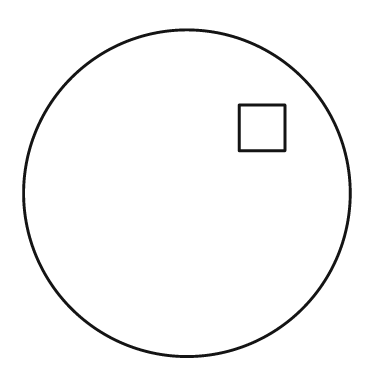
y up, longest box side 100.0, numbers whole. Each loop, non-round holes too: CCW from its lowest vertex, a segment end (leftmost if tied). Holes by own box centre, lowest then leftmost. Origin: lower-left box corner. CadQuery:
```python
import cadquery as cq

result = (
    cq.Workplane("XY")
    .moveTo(50.0, 50.0)
    .circle(50.0)
    .moveTo(66.0, 63.0)
    .lineTo(80.0, 63.0)
    .lineTo(80.0, 77.0)
    .lineTo(66.0, 77.0)
    .close()
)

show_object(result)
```